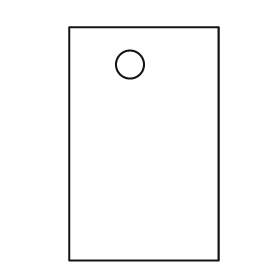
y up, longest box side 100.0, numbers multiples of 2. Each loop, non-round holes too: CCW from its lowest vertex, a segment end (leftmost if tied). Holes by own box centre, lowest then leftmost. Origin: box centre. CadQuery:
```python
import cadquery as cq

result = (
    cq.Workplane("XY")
    .moveTo(-32.0, -50.0)
    .lineTo(32.0, -50.0)
    .lineTo(32.0, 50.0)
    .lineTo(-32.0, 50.0)
    .close()
    .moveTo(-6.0, 34.0)
    .circle(6.0)
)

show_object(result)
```